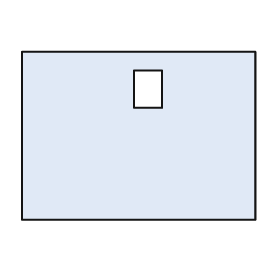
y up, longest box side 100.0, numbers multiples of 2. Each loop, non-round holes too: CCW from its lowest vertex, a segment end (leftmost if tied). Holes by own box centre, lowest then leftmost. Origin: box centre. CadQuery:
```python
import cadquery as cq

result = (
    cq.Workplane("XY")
    .moveTo(-50.0, -36.0)
    .lineTo(50.0, -36.0)
    .lineTo(50.0, 36.0)
    .lineTo(-50.0, 36.0)
    .close()
    .moveTo(-2.0, 12.0)
    .lineTo(10.0, 12.0)
    .lineTo(10.0, 28.0)
    .lineTo(-2.0, 28.0)
    .close()
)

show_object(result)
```